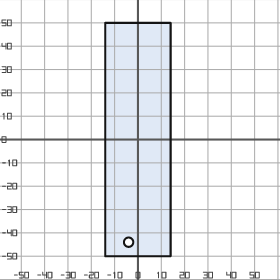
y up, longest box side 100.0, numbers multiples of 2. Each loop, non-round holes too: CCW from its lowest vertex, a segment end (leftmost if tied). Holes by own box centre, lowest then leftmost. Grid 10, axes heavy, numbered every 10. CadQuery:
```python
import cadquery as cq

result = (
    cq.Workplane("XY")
    .moveTo(-14.0, -50.0)
    .lineTo(14.0, -50.0)
    .lineTo(14.0, 50.0)
    .lineTo(-14.0, 50.0)
    .close()
    .moveTo(-4.0, -44.0)
    .circle(2.0)
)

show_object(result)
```